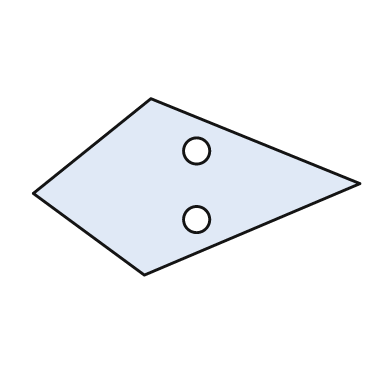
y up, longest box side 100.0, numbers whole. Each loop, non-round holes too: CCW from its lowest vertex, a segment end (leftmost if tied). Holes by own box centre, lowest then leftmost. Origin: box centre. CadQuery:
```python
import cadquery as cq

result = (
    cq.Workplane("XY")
    .moveTo(-16.0, -27.0)
    .lineTo(50.0, 1.0)
    .lineTo(-14.0, 27.0)
    .lineTo(-50.0, -2.0)
    .close()
    .moveTo(0.0, -10.0)
    .circle(4.0)
    .moveTo(0.0, 11.0)
    .circle(4.0)
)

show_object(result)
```